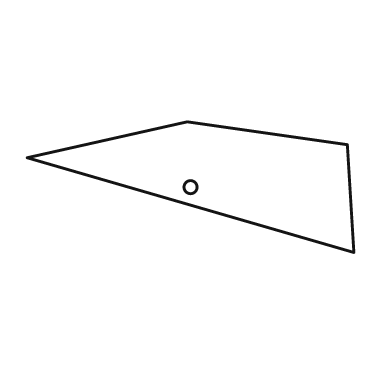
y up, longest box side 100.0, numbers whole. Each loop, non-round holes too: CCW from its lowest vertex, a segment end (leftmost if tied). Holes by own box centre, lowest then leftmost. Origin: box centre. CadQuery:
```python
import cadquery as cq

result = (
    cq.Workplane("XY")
    .moveTo(50.0, -20.0)
    .lineTo(48.0, 13.0)
    .lineTo(-1.0, 20.0)
    .lineTo(-50.0, 9.0)
    .close()
    .moveTo(0.0, 0.0)
    .circle(2.0)
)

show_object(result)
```